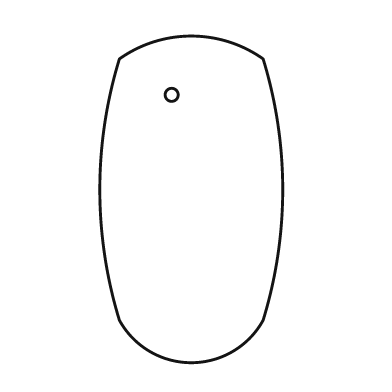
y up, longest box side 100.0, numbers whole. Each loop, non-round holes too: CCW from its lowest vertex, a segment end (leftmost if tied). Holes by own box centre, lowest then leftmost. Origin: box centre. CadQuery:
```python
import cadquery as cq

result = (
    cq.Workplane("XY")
    .moveTo(-22.0, -37.0)
    .threePointArc((0.0, -50.0), (22.0, -37.0))
    .threePointArc((28.0, 3.0), (22.0, 43.0))
    .threePointArc((0.0, 50.0), (-22.0, 43.0))
    .threePointArc((-28.0, 3.0), (-22.0, -37.0))
    .close()
    .moveTo(-6.0, 32.0)
    .circle(2.0)
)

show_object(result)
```